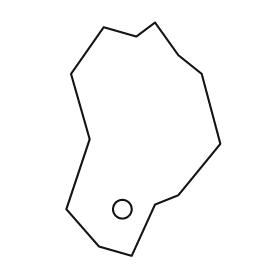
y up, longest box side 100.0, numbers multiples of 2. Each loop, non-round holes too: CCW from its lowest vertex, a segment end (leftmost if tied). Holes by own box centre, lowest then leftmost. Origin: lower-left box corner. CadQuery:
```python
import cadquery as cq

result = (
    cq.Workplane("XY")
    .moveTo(28.0, 0.0)
    .lineTo(38.0, 22.0)
    .lineTo(48.0, 26.0)
    .lineTo(66.0, 48.0)
    .lineTo(58.0, 78.0)
    .lineTo(48.0, 86.0)
    .lineTo(38.0, 100.0)
    .lineTo(30.0, 94.0)
    .lineTo(16.0, 98.0)
    .lineTo(2.0, 78.0)
    .lineTo(10.0, 50.0)
    .lineTo(0.0, 20.0)
    .lineTo(14.0, 4.0)
    .close()
    .moveTo(24.0, 20.0)
    .circle(4.0)
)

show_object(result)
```